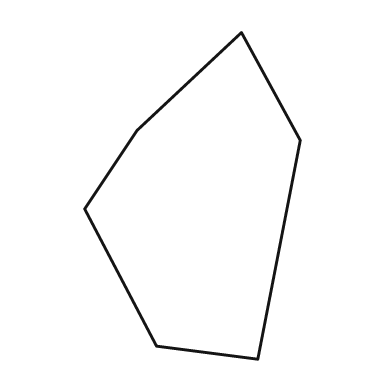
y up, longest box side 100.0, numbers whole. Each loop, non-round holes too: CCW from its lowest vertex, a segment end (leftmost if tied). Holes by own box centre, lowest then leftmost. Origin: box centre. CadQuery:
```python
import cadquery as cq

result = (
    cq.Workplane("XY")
    .moveTo(20.0, -50.0)
    .lineTo(33.0, 17.0)
    .lineTo(15.0, 50.0)
    .lineTo(-17.0, 20.0)
    .lineTo(-33.0, -4.0)
    .lineTo(-11.0, -46.0)
    .close()
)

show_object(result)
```